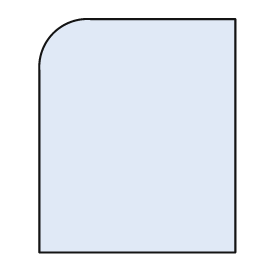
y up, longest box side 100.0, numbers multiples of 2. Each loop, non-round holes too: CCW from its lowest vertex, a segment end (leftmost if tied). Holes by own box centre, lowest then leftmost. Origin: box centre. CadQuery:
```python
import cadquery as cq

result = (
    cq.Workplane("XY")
    .moveTo(-42.0, -50.0)
    .lineTo(42.0, -50.0)
    .lineTo(42.0, 50.0)
    .lineTo(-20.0, 50.0)
    .threePointArc((-36.0, 44.0), (-42.0, 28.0))
    .close()
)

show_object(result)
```